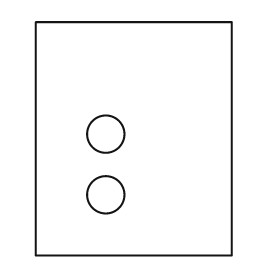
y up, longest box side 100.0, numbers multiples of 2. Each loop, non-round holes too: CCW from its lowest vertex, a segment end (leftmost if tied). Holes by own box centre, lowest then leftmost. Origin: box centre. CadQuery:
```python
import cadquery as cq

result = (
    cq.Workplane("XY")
    .moveTo(-42.0, -50.0)
    .lineTo(42.0, -50.0)
    .lineTo(42.0, 50.0)
    .lineTo(-42.0, 50.0)
    .close()
    .moveTo(-12.0, -24.0)
    .circle(8.0)
    .moveTo(-12.0, 2.0)
    .circle(8.0)
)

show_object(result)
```